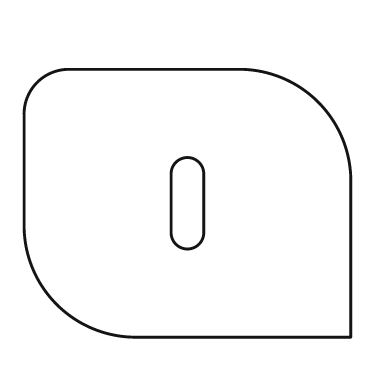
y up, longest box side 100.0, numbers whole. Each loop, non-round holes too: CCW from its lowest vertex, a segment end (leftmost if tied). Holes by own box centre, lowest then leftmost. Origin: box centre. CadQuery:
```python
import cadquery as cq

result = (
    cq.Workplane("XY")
    .moveTo(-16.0, -41.0)
    .lineTo(50.0, -41.0)
    .lineTo(50.0, 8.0)
    .threePointArc((40.0, 31.0), (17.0, 41.0))
    .lineTo(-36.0, 41.0)
    .threePointArc((-46.0, 37.0), (-50.0, 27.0))
    .lineTo(-50.0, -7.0)
    .threePointArc((-40.0, -31.0), (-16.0, -41.0))
    .close()
    .moveTo(-5.0, -9.0)
    .threePointArc((0.0, -14.0), (5.0, -9.0))
    .lineTo(5.0, 9.0)
    .threePointArc((0.0, 14.0), (-5.0, 9.0))
    .close()
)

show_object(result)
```